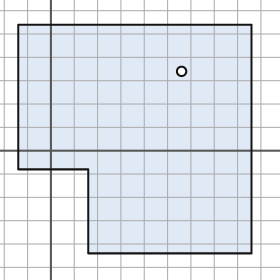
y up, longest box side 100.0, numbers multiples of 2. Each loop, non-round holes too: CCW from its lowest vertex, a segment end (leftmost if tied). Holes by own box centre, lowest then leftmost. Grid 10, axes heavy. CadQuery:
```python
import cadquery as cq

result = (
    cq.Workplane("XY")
    .moveTo(16.0, -44.0)
    .lineTo(86.0, -44.0)
    .lineTo(86.0, 54.0)
    .lineTo(-14.0, 54.0)
    .lineTo(-14.0, -8.0)
    .lineTo(16.0, -8.0)
    .close()
    .moveTo(56.0, 34.0)
    .circle(2.0)
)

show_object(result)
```